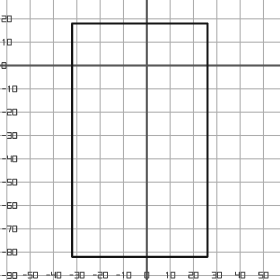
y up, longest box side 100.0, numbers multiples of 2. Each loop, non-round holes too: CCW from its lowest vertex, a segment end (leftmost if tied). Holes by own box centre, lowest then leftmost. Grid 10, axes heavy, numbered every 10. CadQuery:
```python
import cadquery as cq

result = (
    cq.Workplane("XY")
    .moveTo(-32.0, -82.0)
    .lineTo(26.0, -82.0)
    .lineTo(26.0, 18.0)
    .lineTo(-32.0, 18.0)
    .close()
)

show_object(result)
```